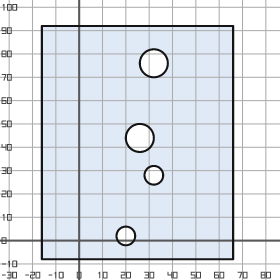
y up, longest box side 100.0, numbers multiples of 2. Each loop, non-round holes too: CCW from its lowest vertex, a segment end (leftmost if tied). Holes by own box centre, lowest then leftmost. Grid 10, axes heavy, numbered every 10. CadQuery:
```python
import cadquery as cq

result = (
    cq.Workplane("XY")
    .moveTo(-16.0, -8.0)
    .lineTo(66.0, -8.0)
    .lineTo(66.0, 92.0)
    .lineTo(-16.0, 92.0)
    .close()
    .moveTo(20.0, 2.0)
    .circle(4.0)
    .moveTo(32.0, 28.0)
    .circle(4.0)
    .moveTo(26.0, 44.0)
    .circle(6.0)
    .moveTo(32.0, 76.0)
    .circle(6.0)
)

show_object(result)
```